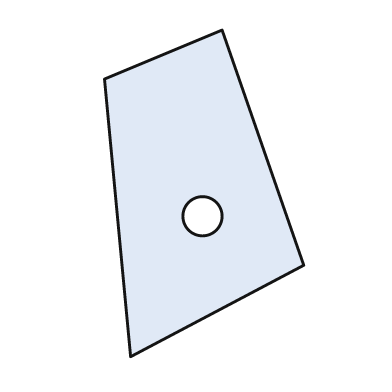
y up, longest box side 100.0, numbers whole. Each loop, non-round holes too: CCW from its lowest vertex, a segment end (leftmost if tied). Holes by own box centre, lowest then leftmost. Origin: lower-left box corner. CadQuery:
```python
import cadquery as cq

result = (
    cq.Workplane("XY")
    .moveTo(8.0, 0.0)
    .lineTo(61.0, 28.0)
    .lineTo(36.0, 100.0)
    .lineTo(0.0, 85.0)
    .close()
    .moveTo(30.0, 43.0)
    .circle(6.0)
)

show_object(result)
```